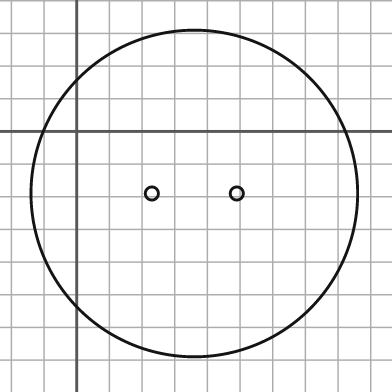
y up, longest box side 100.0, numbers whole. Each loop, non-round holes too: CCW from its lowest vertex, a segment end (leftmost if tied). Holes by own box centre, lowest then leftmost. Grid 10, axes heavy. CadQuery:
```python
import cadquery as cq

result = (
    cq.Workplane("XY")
    .moveTo(36.0, -19.0)
    .circle(50.0)
    .moveTo(23.0, -19.0)
    .circle(2.0)
    .moveTo(49.0, -19.0)
    .circle(2.0)
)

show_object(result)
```